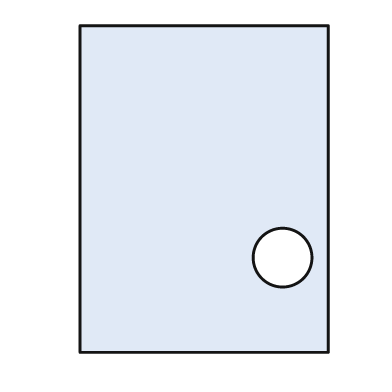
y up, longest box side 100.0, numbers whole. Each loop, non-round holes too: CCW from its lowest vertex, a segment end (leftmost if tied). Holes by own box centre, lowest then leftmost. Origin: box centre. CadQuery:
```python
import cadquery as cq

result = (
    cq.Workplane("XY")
    .moveTo(-38.0, -50.0)
    .lineTo(38.0, -50.0)
    .lineTo(38.0, 50.0)
    .lineTo(-38.0, 50.0)
    .close()
    .moveTo(24.0, -21.0)
    .circle(9.0)
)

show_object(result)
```